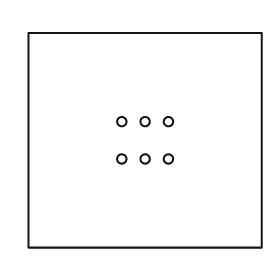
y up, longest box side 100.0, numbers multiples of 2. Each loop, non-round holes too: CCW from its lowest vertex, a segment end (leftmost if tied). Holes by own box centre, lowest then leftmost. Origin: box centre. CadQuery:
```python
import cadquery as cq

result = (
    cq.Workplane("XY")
    .moveTo(-50.0, -46.0)
    .lineTo(50.0, -46.0)
    .lineTo(50.0, 46.0)
    .lineTo(-50.0, 46.0)
    .close()
    .moveTo(-10.0, -8.0)
    .circle(2.0)
    .moveTo(0.0, -8.0)
    .circle(2.0)
    .moveTo(10.0, -8.0)
    .circle(2.0)
    .moveTo(-10.0, 8.0)
    .circle(2.0)
    .moveTo(0.0, 8.0)
    .circle(2.0)
    .moveTo(10.0, 8.0)
    .circle(2.0)
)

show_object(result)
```